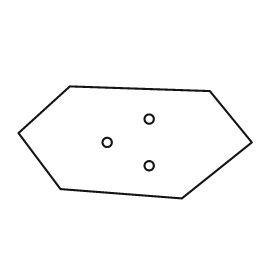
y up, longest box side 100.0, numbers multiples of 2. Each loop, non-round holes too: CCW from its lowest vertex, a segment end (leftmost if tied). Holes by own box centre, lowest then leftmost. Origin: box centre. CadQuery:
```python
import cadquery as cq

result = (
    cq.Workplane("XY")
    .moveTo(20.0, -24.0)
    .lineTo(50.0, 0.0)
    .lineTo(32.0, 22.0)
    .lineTo(-28.0, 24.0)
    .lineTo(-50.0, 4.0)
    .lineTo(-32.0, -20.0)
    .close()
    .moveTo(6.0, -10.0)
    .circle(2.0)
    .moveTo(-12.0, 0.0)
    .circle(2.0)
    .moveTo(6.0, 10.0)
    .circle(2.0)
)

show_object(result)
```